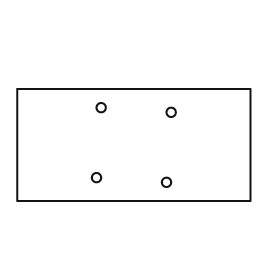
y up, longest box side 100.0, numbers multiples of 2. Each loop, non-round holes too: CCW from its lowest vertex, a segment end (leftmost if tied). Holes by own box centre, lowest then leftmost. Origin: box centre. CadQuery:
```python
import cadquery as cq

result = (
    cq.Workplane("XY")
    .moveTo(-50.0, -24.0)
    .lineTo(50.0, -24.0)
    .lineTo(50.0, 24.0)
    .lineTo(-50.0, 24.0)
    .close()
    .moveTo(14.0, -16.0)
    .circle(2.0)
    .moveTo(-16.0, -14.0)
    .circle(2.0)
    .moveTo(16.0, 14.0)
    .circle(2.0)
    .moveTo(-14.0, 16.0)
    .circle(2.0)
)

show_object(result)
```